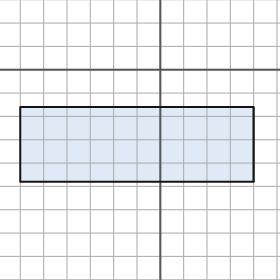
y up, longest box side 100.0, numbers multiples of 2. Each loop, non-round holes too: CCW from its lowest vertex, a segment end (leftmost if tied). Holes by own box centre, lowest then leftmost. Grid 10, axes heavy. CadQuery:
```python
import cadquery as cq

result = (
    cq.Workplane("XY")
    .moveTo(-60.0, -48.0)
    .lineTo(40.0, -48.0)
    .lineTo(40.0, -16.0)
    .lineTo(-60.0, -16.0)
    .close()
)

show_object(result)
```